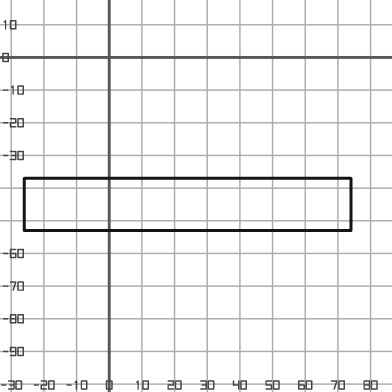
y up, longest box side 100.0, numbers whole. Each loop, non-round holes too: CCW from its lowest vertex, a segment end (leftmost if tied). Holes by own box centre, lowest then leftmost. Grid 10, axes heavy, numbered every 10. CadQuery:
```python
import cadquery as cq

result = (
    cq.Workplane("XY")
    .moveTo(-26.0, -53.0)
    .lineTo(74.0, -53.0)
    .lineTo(74.0, -37.0)
    .lineTo(-26.0, -37.0)
    .close()
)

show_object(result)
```